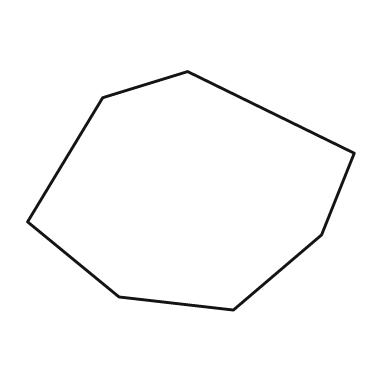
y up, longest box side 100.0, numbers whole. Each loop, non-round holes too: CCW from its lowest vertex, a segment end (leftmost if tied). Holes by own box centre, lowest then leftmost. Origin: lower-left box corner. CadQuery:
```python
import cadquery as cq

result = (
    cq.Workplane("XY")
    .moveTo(63.0, 0.0)
    .lineTo(90.0, 23.0)
    .lineTo(100.0, 48.0)
    .lineTo(49.0, 73.0)
    .lineTo(23.0, 65.0)
    .lineTo(0.0, 27.0)
    .lineTo(28.0, 4.0)
    .close()
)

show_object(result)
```